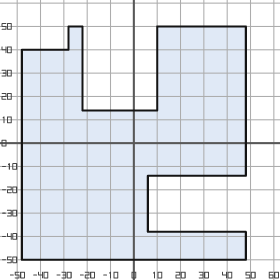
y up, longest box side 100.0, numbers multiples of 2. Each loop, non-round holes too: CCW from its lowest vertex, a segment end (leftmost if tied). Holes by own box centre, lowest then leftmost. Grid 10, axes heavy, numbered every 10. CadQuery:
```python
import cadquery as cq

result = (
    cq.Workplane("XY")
    .moveTo(-48.0, -50.0)
    .lineTo(48.0, -50.0)
    .lineTo(48.0, -38.0)
    .lineTo(6.0, -38.0)
    .lineTo(6.0, -14.0)
    .lineTo(48.0, -14.0)
    .lineTo(48.0, 50.0)
    .lineTo(10.0, 50.0)
    .lineTo(10.0, 14.0)
    .lineTo(-22.0, 14.0)
    .lineTo(-22.0, 50.0)
    .lineTo(-28.0, 50.0)
    .lineTo(-28.0, 40.0)
    .lineTo(-48.0, 40.0)
    .close()
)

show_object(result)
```